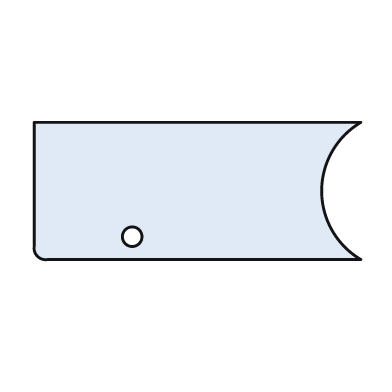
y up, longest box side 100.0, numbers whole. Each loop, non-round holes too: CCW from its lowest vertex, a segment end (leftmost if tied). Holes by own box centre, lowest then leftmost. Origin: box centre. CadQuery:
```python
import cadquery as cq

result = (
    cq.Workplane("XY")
    .moveTo(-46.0, -21.0)
    .lineTo(50.0, -21.0)
    .threePointArc((38.0, 0.0), (50.0, 21.0))
    .lineTo(-50.0, 21.0)
    .lineTo(-50.0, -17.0)
    .threePointArc((-49.0, -20.0), (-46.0, -21.0))
    .close()
    .moveTo(-20.0, -14.0)
    .circle(3.0)
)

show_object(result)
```